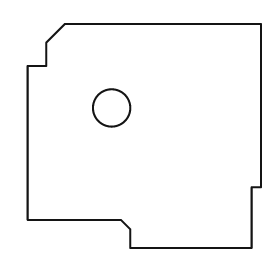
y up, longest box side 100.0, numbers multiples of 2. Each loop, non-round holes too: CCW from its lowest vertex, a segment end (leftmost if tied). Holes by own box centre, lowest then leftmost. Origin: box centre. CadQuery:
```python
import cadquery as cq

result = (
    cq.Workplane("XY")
    .moveTo(-6.0, -48.0)
    .lineTo(46.0, -48.0)
    .lineTo(46.0, -22.0)
    .lineTo(50.0, -22.0)
    .lineTo(50.0, 48.0)
    .lineTo(-34.0, 48.0)
    .lineTo(-42.0, 40.0)
    .lineTo(-42.0, 30.0)
    .lineTo(-50.0, 30.0)
    .lineTo(-50.0, -36.0)
    .lineTo(-10.0, -36.0)
    .lineTo(-6.0, -40.0)
    .close()
    .moveTo(-14.0, 12.0)
    .circle(8.0)
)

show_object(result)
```